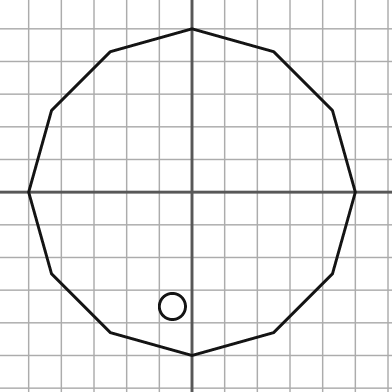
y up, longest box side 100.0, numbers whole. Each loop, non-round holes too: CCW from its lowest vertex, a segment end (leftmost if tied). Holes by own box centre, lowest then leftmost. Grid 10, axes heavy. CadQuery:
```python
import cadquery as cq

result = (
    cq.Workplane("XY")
    .moveTo(0.0, -50.0)
    .lineTo(25.0, -43.0)
    .lineTo(43.0, -25.0)
    .lineTo(50.0, 0.0)
    .lineTo(43.0, 25.0)
    .lineTo(25.0, 43.0)
    .lineTo(0.0, 50.0)
    .lineTo(-25.0, 43.0)
    .lineTo(-43.0, 25.0)
    .lineTo(-50.0, 0.0)
    .lineTo(-43.0, -25.0)
    .lineTo(-25.0, -43.0)
    .close()
    .moveTo(-6.0, -35.0)
    .circle(4.0)
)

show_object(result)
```